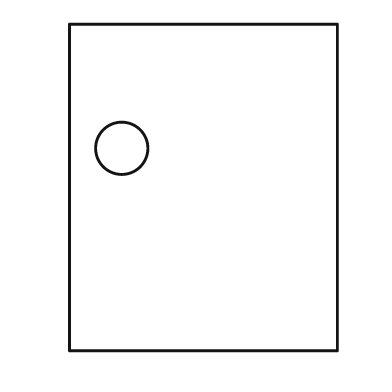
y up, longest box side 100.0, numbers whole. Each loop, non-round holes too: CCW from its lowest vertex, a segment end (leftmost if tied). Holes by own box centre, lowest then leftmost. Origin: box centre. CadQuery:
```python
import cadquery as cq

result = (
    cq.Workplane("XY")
    .moveTo(-41.0, -50.0)
    .lineTo(41.0, -50.0)
    .lineTo(41.0, 50.0)
    .lineTo(-41.0, 50.0)
    .close()
    .moveTo(-25.0, 12.0)
    .circle(8.0)
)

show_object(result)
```